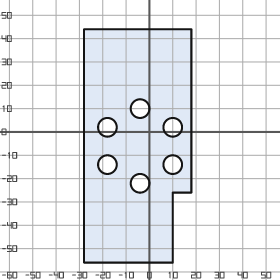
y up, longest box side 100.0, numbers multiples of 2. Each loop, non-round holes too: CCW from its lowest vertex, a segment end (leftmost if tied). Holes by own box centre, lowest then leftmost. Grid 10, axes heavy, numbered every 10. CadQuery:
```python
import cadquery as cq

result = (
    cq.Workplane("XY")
    .moveTo(-28.0, -56.0)
    .lineTo(10.0, -56.0)
    .lineTo(10.0, -26.0)
    .lineTo(18.0, -26.0)
    .lineTo(18.0, 44.0)
    .lineTo(-28.0, 44.0)
    .close()
    .moveTo(-4.0, -22.0)
    .circle(4.0)
    .moveTo(-18.0, -14.0)
    .circle(4.0)
    .moveTo(10.0, -14.0)
    .circle(4.0)
    .moveTo(-18.0, 2.0)
    .circle(4.0)
    .moveTo(10.0, 2.0)
    .circle(4.0)
    .moveTo(-4.0, 10.0)
    .circle(4.0)
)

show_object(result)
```